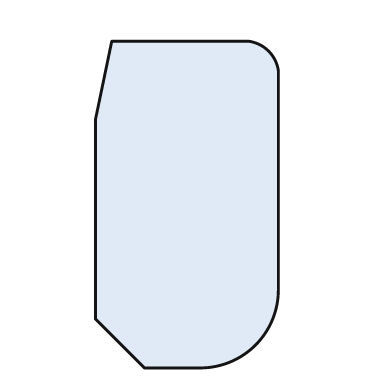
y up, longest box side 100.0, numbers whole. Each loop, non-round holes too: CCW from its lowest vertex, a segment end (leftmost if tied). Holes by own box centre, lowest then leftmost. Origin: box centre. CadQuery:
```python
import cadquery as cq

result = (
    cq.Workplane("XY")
    .moveTo(-13.0, -50.0)
    .lineTo(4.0, -50.0)
    .threePointArc((21.0, -43.0), (28.0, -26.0))
    .lineTo(28.0, 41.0)
    .threePointArc((25.0, 47.0), (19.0, 50.0))
    .lineTo(-23.0, 50.0)
    .lineTo(-28.0, 26.0)
    .lineTo(-28.0, -35.0)
    .close()
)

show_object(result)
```